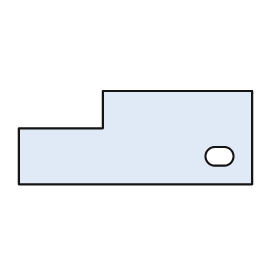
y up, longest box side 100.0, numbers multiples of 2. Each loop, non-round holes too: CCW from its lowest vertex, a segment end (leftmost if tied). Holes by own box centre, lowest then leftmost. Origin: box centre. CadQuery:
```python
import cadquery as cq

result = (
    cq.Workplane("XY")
    .moveTo(-50.0, -20.0)
    .lineTo(50.0, -20.0)
    .lineTo(50.0, 20.0)
    .lineTo(-14.0, 20.0)
    .lineTo(-14.0, 4.0)
    .lineTo(-50.0, 4.0)
    .close()
    .moveTo(34.0, -12.0)
    .lineTo(38.0, -12.0)
    .threePointArc((42.0, -8.0), (38.0, -4.0))
    .lineTo(34.0, -4.0)
    .threePointArc((30.0, -8.0), (34.0, -12.0))
    .close()
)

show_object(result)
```